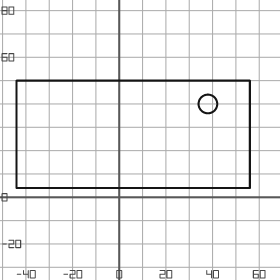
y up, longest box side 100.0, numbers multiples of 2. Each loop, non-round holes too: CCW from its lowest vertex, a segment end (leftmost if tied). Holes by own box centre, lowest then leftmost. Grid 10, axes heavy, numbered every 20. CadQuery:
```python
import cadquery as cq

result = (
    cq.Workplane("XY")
    .moveTo(-44.0, 4.0)
    .lineTo(56.0, 4.0)
    .lineTo(56.0, 50.0)
    .lineTo(-44.0, 50.0)
    .close()
    .moveTo(38.0, 40.0)
    .circle(4.0)
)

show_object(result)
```